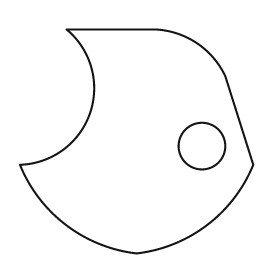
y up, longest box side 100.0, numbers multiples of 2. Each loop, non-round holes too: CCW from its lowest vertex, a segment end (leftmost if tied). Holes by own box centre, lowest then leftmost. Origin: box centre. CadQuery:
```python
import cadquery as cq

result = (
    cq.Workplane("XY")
    .moveTo(0.0, -48.0)
    .threePointArc((30.0, -36.0), (50.0, -10.0))
    .lineTo(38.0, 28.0)
    .threePointArc((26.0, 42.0), (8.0, 48.0))
    .lineTo(-30.0, 48.0)
    .threePointArc((-20.0, 12.0), (-50.0, -10.0))
    .threePointArc((-30.0, -36.0), (0.0, -48.0))
    .close()
    .moveTo(28.0, -2.0)
    .circle(10.0)
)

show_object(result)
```